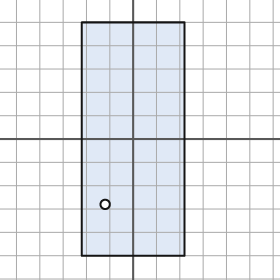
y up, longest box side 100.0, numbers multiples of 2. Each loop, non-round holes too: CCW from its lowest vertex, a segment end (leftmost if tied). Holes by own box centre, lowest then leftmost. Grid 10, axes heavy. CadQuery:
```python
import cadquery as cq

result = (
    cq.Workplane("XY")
    .moveTo(-22.0, -50.0)
    .lineTo(22.0, -50.0)
    .lineTo(22.0, 50.0)
    .lineTo(-22.0, 50.0)
    .close()
    .moveTo(-12.0, -28.0)
    .circle(2.0)
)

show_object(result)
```